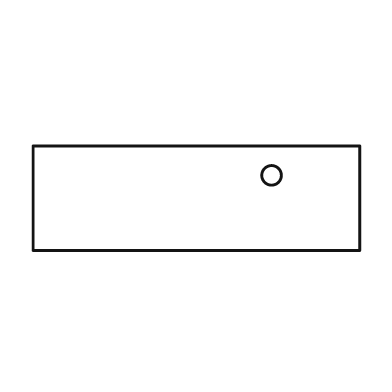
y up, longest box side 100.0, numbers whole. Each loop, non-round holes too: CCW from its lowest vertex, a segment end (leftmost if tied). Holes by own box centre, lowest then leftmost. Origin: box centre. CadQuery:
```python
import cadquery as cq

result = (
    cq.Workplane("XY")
    .moveTo(-50.0, -16.0)
    .lineTo(50.0, -16.0)
    .lineTo(50.0, 16.0)
    .lineTo(-50.0, 16.0)
    .close()
    .moveTo(23.0, 7.0)
    .circle(3.0)
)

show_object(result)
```